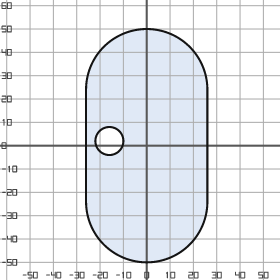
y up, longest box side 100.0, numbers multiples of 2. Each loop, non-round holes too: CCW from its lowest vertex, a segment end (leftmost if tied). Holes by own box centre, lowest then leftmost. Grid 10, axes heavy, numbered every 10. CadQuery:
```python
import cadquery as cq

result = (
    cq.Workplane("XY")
    .moveTo(-26.0, -24.0)
    .threePointArc((0.0, -50.0), (26.0, -24.0))
    .lineTo(26.0, 24.0)
    .threePointArc((0.0, 50.0), (-26.0, 24.0))
    .close()
    .moveTo(-16.0, 2.0)
    .circle(6.0)
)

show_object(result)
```